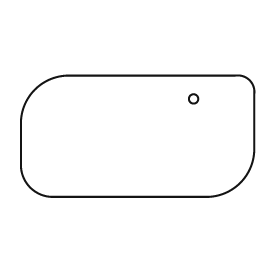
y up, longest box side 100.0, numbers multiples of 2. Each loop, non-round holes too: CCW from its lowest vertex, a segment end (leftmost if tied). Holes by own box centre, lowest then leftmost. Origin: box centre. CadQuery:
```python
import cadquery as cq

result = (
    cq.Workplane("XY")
    .moveTo(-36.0, -26.0)
    .lineTo(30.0, -26.0)
    .threePointArc((44.0, -20.0), (50.0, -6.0))
    .lineTo(50.0, 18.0)
    .threePointArc((48.0, 24.0), (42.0, 26.0))
    .lineTo(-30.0, 26.0)
    .threePointArc((-44.0, 20.0), (-50.0, 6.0))
    .lineTo(-50.0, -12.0)
    .threePointArc((-46.0, -22.0), (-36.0, -26.0))
    .close()
    .moveTo(24.0, 16.0)
    .circle(2.0)
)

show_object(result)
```